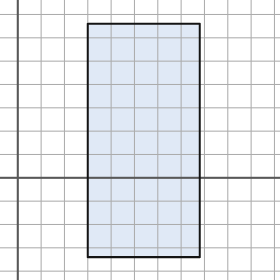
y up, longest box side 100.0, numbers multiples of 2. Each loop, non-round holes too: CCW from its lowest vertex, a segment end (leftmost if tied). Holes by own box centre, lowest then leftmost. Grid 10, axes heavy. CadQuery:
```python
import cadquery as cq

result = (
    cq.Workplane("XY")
    .moveTo(30.0, -34.0)
    .lineTo(78.0, -34.0)
    .lineTo(78.0, 66.0)
    .lineTo(30.0, 66.0)
    .close()
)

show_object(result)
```